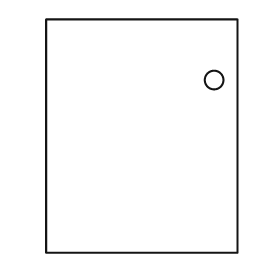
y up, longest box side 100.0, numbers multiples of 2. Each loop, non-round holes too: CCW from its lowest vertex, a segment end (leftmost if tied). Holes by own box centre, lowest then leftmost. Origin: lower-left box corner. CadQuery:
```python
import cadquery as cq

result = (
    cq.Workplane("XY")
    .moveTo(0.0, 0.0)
    .lineTo(82.0, 0.0)
    .lineTo(82.0, 100.0)
    .lineTo(0.0, 100.0)
    .close()
    .moveTo(72.0, 74.0)
    .circle(4.0)
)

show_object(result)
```